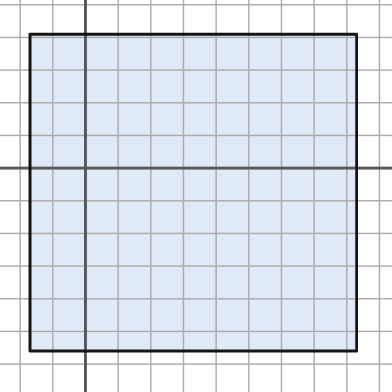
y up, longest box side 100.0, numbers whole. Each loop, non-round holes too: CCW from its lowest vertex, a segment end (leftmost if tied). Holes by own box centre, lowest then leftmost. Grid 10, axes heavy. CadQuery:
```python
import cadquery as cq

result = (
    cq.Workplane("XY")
    .moveTo(-17.0, -56.0)
    .lineTo(83.0, -56.0)
    .lineTo(83.0, 41.0)
    .lineTo(-17.0, 41.0)
    .close()
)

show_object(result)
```